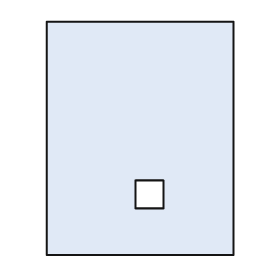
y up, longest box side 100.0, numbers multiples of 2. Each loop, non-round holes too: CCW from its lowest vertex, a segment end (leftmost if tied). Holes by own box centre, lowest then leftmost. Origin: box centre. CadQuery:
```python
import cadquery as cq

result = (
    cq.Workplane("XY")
    .moveTo(-40.0, -50.0)
    .lineTo(40.0, -50.0)
    .lineTo(40.0, 50.0)
    .lineTo(-40.0, 50.0)
    .close()
    .moveTo(-2.0, -30.0)
    .lineTo(10.0, -30.0)
    .lineTo(10.0, -18.0)
    .lineTo(-2.0, -18.0)
    .close()
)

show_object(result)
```